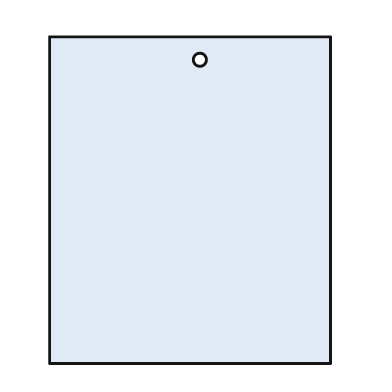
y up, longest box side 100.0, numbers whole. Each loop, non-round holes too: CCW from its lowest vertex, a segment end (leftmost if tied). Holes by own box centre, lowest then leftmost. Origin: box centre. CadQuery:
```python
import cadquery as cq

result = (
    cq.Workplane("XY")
    .moveTo(-43.0, -50.0)
    .lineTo(43.0, -50.0)
    .lineTo(43.0, 50.0)
    .lineTo(-43.0, 50.0)
    .close()
    .moveTo(3.0, 43.0)
    .circle(2.0)
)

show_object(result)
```